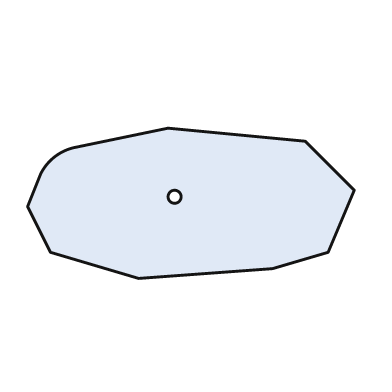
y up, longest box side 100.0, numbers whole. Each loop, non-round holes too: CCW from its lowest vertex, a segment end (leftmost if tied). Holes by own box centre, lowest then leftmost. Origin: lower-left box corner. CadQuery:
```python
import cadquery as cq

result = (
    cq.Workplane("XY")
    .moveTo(34.0, 0.0)
    .lineTo(75.0, 3.0)
    .lineTo(92.0, 8.0)
    .lineTo(100.0, 27.0)
    .lineTo(85.0, 42.0)
    .lineTo(43.0, 46.0)
    .lineTo(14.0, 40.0)
    .threePointArc((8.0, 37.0), (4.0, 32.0))
    .lineTo(0.0, 22.0)
    .lineTo(7.0, 8.0)
    .close()
    .moveTo(45.0, 25.0)
    .circle(2.0)
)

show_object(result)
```